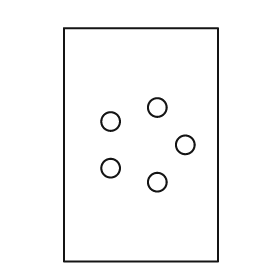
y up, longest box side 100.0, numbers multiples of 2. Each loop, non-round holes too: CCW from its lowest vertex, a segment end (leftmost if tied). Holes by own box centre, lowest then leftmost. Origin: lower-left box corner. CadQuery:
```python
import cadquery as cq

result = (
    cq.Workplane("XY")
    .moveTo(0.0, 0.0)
    .lineTo(66.0, 0.0)
    .lineTo(66.0, 100.0)
    .lineTo(0.0, 100.0)
    .close()
    .moveTo(40.0, 34.0)
    .circle(4.0)
    .moveTo(20.0, 40.0)
    .circle(4.0)
    .moveTo(52.0, 50.0)
    .circle(4.0)
    .moveTo(20.0, 60.0)
    .circle(4.0)
    .moveTo(40.0, 66.0)
    .circle(4.0)
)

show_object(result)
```